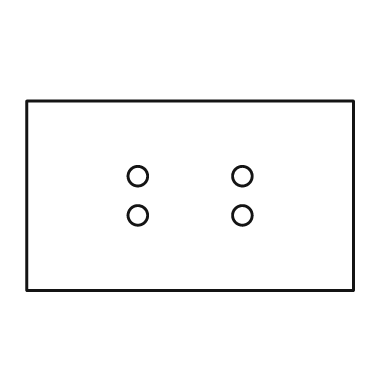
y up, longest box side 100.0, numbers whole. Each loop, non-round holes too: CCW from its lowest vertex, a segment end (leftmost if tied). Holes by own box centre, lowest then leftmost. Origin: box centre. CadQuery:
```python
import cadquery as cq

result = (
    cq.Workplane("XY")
    .moveTo(-50.0, -29.0)
    .lineTo(50.0, -29.0)
    .lineTo(50.0, 29.0)
    .lineTo(-50.0, 29.0)
    .close()
    .moveTo(-16.0, -6.0)
    .circle(3.0)
    .moveTo(16.0, -6.0)
    .circle(3.0)
    .moveTo(-16.0, 6.0)
    .circle(3.0)
    .moveTo(16.0, 6.0)
    .circle(3.0)
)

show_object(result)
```